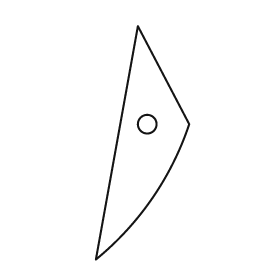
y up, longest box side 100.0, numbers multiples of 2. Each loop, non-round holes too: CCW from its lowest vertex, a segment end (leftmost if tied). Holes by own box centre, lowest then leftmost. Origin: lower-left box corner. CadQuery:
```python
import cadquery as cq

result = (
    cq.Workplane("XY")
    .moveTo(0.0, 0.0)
    .threePointArc((24.0, 26.0), (40.0, 58.0))
    .lineTo(18.0, 100.0)
    .close()
    .moveTo(22.0, 58.0)
    .circle(4.0)
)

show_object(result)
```